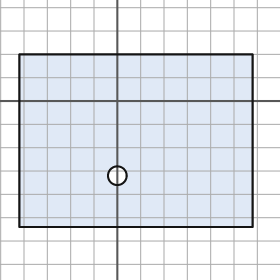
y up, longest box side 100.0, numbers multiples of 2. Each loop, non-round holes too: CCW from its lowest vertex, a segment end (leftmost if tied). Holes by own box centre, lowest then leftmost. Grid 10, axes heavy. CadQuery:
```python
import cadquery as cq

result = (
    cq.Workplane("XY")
    .moveTo(-42.0, -54.0)
    .lineTo(58.0, -54.0)
    .lineTo(58.0, 20.0)
    .lineTo(-42.0, 20.0)
    .close()
    .moveTo(0.0, -32.0)
    .circle(4.0)
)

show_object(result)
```